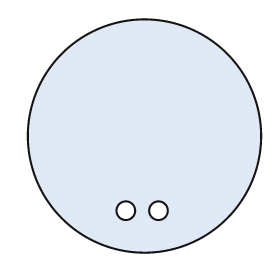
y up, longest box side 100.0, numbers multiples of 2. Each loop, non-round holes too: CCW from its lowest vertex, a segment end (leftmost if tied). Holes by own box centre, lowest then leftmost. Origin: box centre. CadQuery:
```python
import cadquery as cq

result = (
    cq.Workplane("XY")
    .moveTo(0.0, 0.0)
    .circle(50.0)
    .moveTo(-8.0, -32.0)
    .circle(4.0)
    .moveTo(6.0, -32.0)
    .circle(4.0)
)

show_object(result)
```